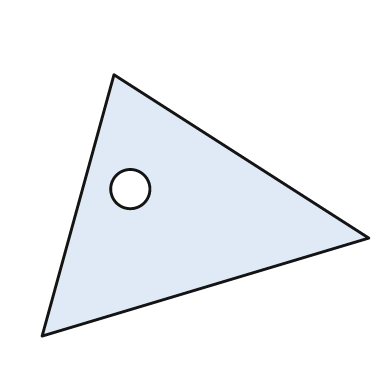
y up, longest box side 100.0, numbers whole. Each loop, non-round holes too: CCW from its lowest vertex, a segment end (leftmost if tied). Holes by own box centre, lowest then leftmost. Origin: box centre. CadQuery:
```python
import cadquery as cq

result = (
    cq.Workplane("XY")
    .moveTo(-50.0, -40.0)
    .lineTo(50.0, -10.0)
    .lineTo(-28.0, 40.0)
    .close()
    .moveTo(-23.0, 5.0)
    .circle(6.0)
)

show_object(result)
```